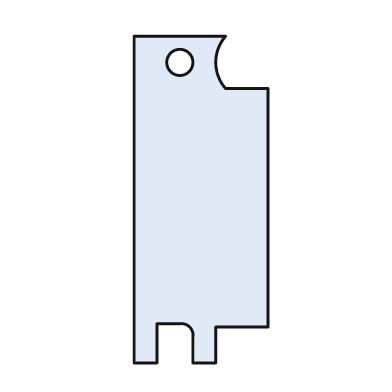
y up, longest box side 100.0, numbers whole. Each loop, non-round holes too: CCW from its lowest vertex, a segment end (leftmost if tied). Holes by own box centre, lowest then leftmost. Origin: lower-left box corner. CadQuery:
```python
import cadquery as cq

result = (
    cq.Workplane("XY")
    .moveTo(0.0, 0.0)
    .lineTo(7.0, 0.0)
    .lineTo(7.0, 12.0)
    .lineTo(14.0, 12.0)
    .threePointArc((17.0, 11.0), (18.0, 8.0))
    .lineTo(18.0, 0.0)
    .lineTo(25.0, 0.0)
    .lineTo(25.0, 11.0)
    .lineTo(41.0, 11.0)
    .lineTo(41.0, 84.0)
    .lineTo(28.0, 84.0)
    .threePointArc((25.0, 92.0), (28.0, 100.0))
    .lineTo(0.0, 100.0)
    .close()
    .moveTo(14.0, 92.0)
    .circle(4.0)
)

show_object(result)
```